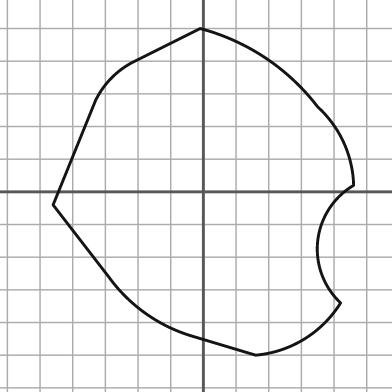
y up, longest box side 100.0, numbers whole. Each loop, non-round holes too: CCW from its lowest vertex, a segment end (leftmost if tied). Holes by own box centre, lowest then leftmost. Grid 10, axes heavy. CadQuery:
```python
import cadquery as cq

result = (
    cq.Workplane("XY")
    .moveTo(16.0, -50.0)
    .threePointArc((31.0, -45.0), (42.0, -34.0))
    .threePointArc((35.0, -15.0), (46.0, 2.0))
    .threePointArc((43.0, 15.0), (35.0, 26.0))
    .threePointArc((19.0, 41.0), (-1.0, 50.0))
    .lineTo(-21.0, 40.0)
    .threePointArc((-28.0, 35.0), (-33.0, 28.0))
    .lineTo(-46.0, -4.0)
    .lineTo(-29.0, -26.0)
    .threePointArc((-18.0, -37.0), (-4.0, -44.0))
    .close()
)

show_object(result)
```